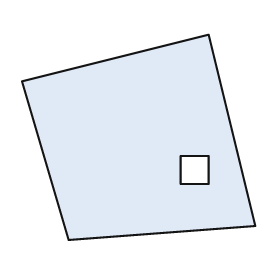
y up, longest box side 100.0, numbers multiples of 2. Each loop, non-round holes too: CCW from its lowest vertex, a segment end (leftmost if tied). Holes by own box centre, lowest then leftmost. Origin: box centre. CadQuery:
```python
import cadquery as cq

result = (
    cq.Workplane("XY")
    .moveTo(-30.0, -44.0)
    .lineTo(50.0, -38.0)
    .lineTo(30.0, 44.0)
    .lineTo(-50.0, 24.0)
    .close()
    .moveTo(18.0, -20.0)
    .lineTo(30.0, -20.0)
    .lineTo(30.0, -8.0)
    .lineTo(18.0, -8.0)
    .close()
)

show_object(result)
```